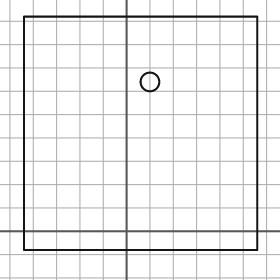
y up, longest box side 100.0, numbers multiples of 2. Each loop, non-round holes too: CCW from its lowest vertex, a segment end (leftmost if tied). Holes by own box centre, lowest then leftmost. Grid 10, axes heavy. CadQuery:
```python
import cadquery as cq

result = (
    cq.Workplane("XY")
    .moveTo(-44.0, -8.0)
    .lineTo(56.0, -8.0)
    .lineTo(56.0, 92.0)
    .lineTo(-44.0, 92.0)
    .close()
    .moveTo(10.0, 64.0)
    .circle(4.0)
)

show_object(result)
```